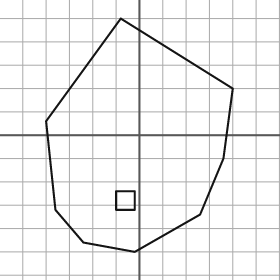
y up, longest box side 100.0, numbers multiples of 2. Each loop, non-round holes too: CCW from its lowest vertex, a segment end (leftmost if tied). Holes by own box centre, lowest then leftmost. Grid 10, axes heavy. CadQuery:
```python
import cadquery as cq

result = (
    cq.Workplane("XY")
    .moveTo(-2.0, -50.0)
    .lineTo(26.0, -34.0)
    .lineTo(36.0, -10.0)
    .lineTo(40.0, 20.0)
    .lineTo(-8.0, 50.0)
    .lineTo(-40.0, 6.0)
    .lineTo(-36.0, -32.0)
    .lineTo(-24.0, -46.0)
    .close()
    .moveTo(-10.0, -32.0)
    .lineTo(-2.0, -32.0)
    .lineTo(-2.0, -24.0)
    .lineTo(-10.0, -24.0)
    .close()
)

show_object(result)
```